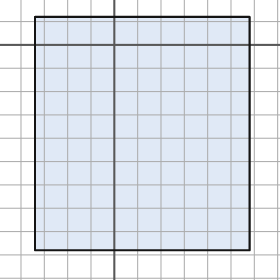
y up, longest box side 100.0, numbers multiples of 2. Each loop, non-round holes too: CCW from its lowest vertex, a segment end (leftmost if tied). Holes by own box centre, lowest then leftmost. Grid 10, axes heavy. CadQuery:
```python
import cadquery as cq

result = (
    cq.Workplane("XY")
    .moveTo(-34.0, -88.0)
    .lineTo(58.0, -88.0)
    .lineTo(58.0, 12.0)
    .lineTo(-34.0, 12.0)
    .close()
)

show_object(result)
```